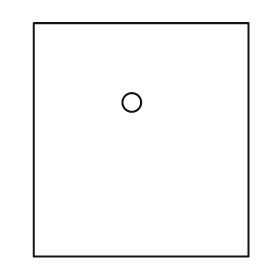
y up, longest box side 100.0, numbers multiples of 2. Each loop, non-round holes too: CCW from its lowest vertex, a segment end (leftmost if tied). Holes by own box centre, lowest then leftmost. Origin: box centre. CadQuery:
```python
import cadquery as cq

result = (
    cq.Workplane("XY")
    .moveTo(-46.0, -50.0)
    .lineTo(46.0, -50.0)
    .lineTo(46.0, 50.0)
    .lineTo(-46.0, 50.0)
    .close()
    .moveTo(-4.0, 16.0)
    .circle(4.0)
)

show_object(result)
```